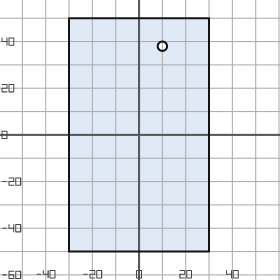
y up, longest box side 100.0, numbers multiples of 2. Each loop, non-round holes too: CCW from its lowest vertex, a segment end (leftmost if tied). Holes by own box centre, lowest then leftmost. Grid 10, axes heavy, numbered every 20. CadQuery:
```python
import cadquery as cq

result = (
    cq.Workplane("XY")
    .moveTo(-30.0, -50.0)
    .lineTo(30.0, -50.0)
    .lineTo(30.0, 50.0)
    .lineTo(-30.0, 50.0)
    .close()
    .moveTo(10.0, 38.0)
    .circle(2.0)
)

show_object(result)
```